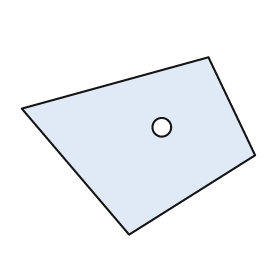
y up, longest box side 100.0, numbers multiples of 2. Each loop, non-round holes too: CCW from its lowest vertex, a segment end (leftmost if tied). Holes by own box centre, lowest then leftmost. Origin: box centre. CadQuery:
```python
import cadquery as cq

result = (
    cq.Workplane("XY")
    .moveTo(-4.0, -38.0)
    .lineTo(50.0, -4.0)
    .lineTo(30.0, 38.0)
    .lineTo(-50.0, 16.0)
    .close()
    .moveTo(10.0, 8.0)
    .circle(4.0)
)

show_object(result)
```